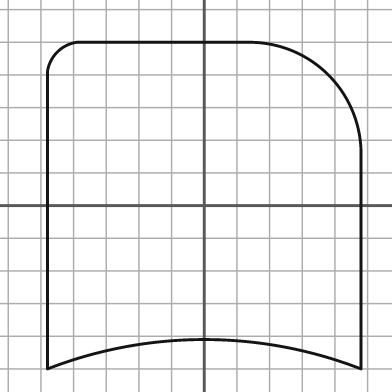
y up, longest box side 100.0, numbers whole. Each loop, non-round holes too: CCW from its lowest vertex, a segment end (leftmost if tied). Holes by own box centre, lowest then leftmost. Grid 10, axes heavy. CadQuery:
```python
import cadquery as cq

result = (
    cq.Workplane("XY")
    .moveTo(-48.0, -50.0)
    .threePointArc((0.0, -41.0), (48.0, -50.0))
    .lineTo(48.0, 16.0)
    .threePointArc((38.0, 40.0), (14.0, 50.0))
    .lineTo(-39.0, 50.0)
    .threePointArc((-45.0, 47.0), (-48.0, 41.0))
    .close()
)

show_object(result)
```